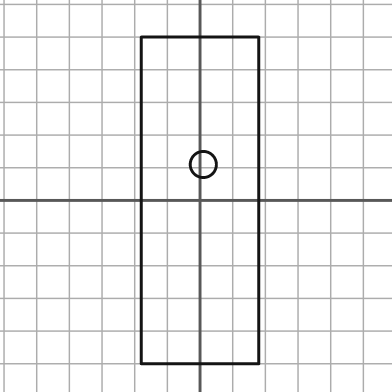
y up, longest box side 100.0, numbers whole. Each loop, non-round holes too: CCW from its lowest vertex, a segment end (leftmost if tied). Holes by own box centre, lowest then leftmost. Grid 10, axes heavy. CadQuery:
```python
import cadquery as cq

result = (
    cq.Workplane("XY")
    .moveTo(-18.0, -50.0)
    .lineTo(18.0, -50.0)
    .lineTo(18.0, 50.0)
    .lineTo(-18.0, 50.0)
    .close()
    .moveTo(1.0, 11.0)
    .circle(4.0)
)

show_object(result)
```